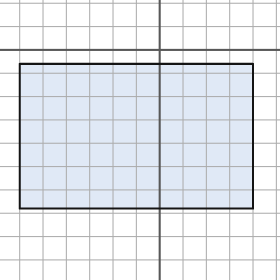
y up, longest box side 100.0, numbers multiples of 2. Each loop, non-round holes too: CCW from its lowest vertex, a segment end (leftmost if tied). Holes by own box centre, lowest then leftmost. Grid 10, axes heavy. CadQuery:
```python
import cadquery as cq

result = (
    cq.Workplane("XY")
    .moveTo(-60.0, -68.0)
    .lineTo(40.0, -68.0)
    .lineTo(40.0, -6.0)
    .lineTo(-60.0, -6.0)
    .close()
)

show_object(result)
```